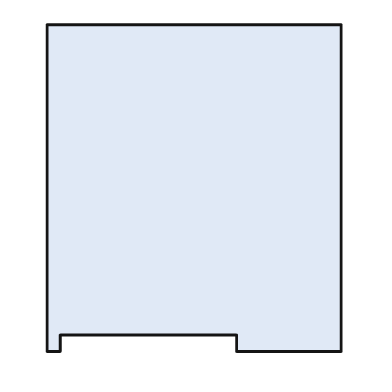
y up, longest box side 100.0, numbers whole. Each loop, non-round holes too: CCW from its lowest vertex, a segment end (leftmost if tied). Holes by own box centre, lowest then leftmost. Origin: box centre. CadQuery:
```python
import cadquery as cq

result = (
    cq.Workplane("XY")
    .moveTo(-45.0, -50.0)
    .lineTo(-41.0, -50.0)
    .lineTo(-41.0, -45.0)
    .lineTo(13.0, -45.0)
    .lineTo(13.0, -50.0)
    .lineTo(45.0, -50.0)
    .lineTo(45.0, 50.0)
    .lineTo(-45.0, 50.0)
    .close()
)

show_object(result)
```